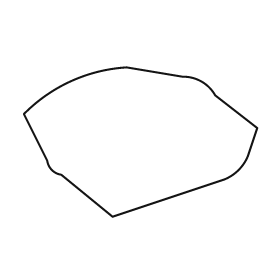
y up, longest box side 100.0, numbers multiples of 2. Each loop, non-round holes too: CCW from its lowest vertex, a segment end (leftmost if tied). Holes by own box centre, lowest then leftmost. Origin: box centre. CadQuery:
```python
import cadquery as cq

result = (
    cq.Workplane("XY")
    .moveTo(-12.0, -32.0)
    .lineTo(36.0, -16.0)
    .threePointArc((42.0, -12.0), (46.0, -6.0))
    .lineTo(50.0, 6.0)
    .lineTo(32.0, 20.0)
    .threePointArc((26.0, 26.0), (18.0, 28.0))
    .lineTo(-6.0, 32.0)
    .threePointArc((-30.0, 26.0), (-50.0, 12.0))
    .lineTo(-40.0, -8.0)
    .threePointArc((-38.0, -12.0), (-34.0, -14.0))
    .close()
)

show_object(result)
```